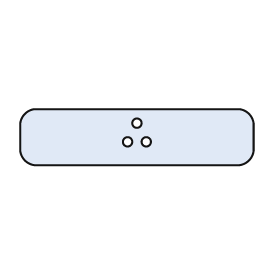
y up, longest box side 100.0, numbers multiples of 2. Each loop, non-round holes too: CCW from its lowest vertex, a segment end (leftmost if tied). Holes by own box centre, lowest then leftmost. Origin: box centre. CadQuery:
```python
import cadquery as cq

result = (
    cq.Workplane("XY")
    .moveTo(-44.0, -12.0)
    .lineTo(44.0, -12.0)
    .threePointArc((48.0, -10.0), (50.0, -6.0))
    .lineTo(50.0, 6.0)
    .threePointArc((48.0, 10.0), (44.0, 12.0))
    .lineTo(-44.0, 12.0)
    .threePointArc((-48.0, 10.0), (-50.0, 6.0))
    .lineTo(-50.0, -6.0)
    .threePointArc((-48.0, -10.0), (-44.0, -12.0))
    .close()
    .moveTo(-4.0, -2.0)
    .circle(2.0)
    .moveTo(4.0, -2.0)
    .circle(2.0)
    .moveTo(0.0, 6.0)
    .circle(2.0)
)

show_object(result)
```